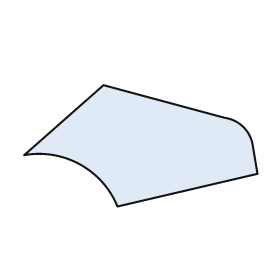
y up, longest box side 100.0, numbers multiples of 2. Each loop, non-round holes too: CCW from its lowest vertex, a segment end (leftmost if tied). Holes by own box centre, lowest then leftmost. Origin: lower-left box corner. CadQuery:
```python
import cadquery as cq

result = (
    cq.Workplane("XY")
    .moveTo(40.0, 0.0)
    .lineTo(100.0, 14.0)
    .lineTo(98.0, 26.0)
    .threePointArc((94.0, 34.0), (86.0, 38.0))
    .lineTo(34.0, 52.0)
    .lineTo(0.0, 22.0)
    .threePointArc((24.0, 18.0), (40.0, 0.0))
    .close()
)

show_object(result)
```